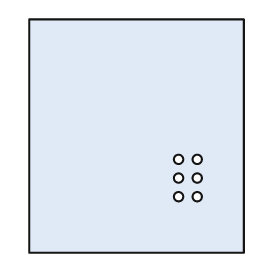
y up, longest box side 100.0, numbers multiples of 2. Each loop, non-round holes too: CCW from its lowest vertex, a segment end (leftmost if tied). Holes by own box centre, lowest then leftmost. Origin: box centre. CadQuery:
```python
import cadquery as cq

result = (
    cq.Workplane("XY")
    .moveTo(-46.0, -50.0)
    .lineTo(46.0, -50.0)
    .lineTo(46.0, 50.0)
    .lineTo(-46.0, 50.0)
    .close()
    .moveTo(18.0, -26.0)
    .circle(2.0)
    .moveTo(26.0, -26.0)
    .circle(2.0)
    .moveTo(18.0, -18.0)
    .circle(2.0)
    .moveTo(26.0, -18.0)
    .circle(2.0)
    .moveTo(18.0, -10.0)
    .circle(2.0)
    .moveTo(26.0, -10.0)
    .circle(2.0)
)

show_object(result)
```